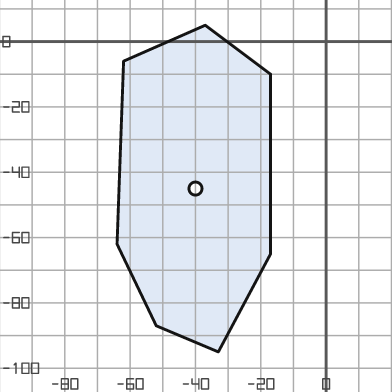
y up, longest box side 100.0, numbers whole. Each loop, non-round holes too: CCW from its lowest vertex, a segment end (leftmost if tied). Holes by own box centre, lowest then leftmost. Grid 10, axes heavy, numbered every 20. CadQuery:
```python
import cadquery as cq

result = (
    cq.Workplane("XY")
    .moveTo(-33.0, -95.0)
    .lineTo(-17.0, -65.0)
    .lineTo(-17.0, -10.0)
    .lineTo(-37.0, 5.0)
    .lineTo(-62.0, -6.0)
    .lineTo(-64.0, -62.0)
    .lineTo(-52.0, -87.0)
    .close()
    .moveTo(-40.0, -45.0)
    .circle(2.0)
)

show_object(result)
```